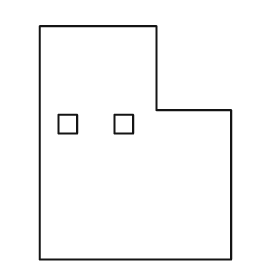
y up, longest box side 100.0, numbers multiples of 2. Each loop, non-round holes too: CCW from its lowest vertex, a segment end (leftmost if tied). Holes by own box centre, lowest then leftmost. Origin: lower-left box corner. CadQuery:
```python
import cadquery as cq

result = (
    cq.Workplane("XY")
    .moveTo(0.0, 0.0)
    .lineTo(82.0, 0.0)
    .lineTo(82.0, 64.0)
    .lineTo(50.0, 64.0)
    .lineTo(50.0, 100.0)
    .lineTo(0.0, 100.0)
    .close()
    .moveTo(8.0, 54.0)
    .lineTo(16.0, 54.0)
    .lineTo(16.0, 62.0)
    .lineTo(8.0, 62.0)
    .close()
    .moveTo(32.0, 54.0)
    .lineTo(40.0, 54.0)
    .lineTo(40.0, 62.0)
    .lineTo(32.0, 62.0)
    .close()
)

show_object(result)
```